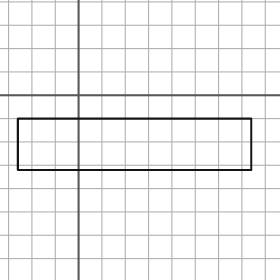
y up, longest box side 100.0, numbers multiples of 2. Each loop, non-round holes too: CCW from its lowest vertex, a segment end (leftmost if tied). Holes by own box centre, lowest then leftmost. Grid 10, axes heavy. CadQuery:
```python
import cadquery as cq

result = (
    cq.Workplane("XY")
    .moveTo(-26.0, -32.0)
    .lineTo(74.0, -32.0)
    .lineTo(74.0, -10.0)
    .lineTo(-26.0, -10.0)
    .close()
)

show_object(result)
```